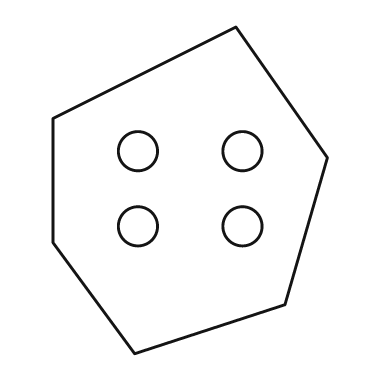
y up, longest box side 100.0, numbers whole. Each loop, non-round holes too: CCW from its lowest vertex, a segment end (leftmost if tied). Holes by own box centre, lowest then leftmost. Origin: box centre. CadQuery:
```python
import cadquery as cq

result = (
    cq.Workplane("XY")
    .moveTo(-17.0, -50.0)
    .lineTo(29.0, -35.0)
    .lineTo(42.0, 10.0)
    .lineTo(14.0, 50.0)
    .lineTo(-42.0, 22.0)
    .lineTo(-42.0, -16.0)
    .close()
    .moveTo(-16.0, -11.0)
    .circle(6.0)
    .moveTo(16.0, -11.0)
    .circle(6.0)
    .moveTo(-16.0, 12.0)
    .circle(6.0)
    .moveTo(16.0, 12.0)
    .circle(6.0)
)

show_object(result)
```